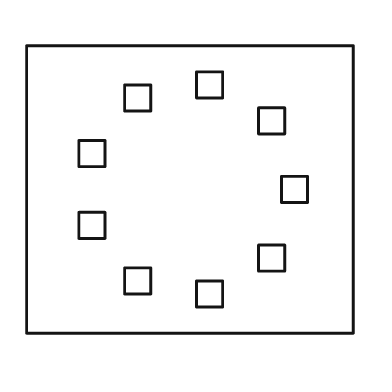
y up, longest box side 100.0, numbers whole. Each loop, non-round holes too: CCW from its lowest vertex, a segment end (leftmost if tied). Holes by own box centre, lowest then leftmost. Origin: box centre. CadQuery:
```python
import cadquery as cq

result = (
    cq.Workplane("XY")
    .moveTo(-50.0, -44.0)
    .lineTo(50.0, -44.0)
    .lineTo(50.0, 44.0)
    .lineTo(-50.0, 44.0)
    .close()
    .moveTo(2.0, -36.0)
    .lineTo(10.0, -36.0)
    .lineTo(10.0, -28.0)
    .lineTo(2.0, -28.0)
    .close()
    .moveTo(-20.0, -32.0)
    .lineTo(-12.0, -32.0)
    .lineTo(-12.0, -24.0)
    .lineTo(-20.0, -24.0)
    .close()
    .moveTo(21.0, -25.0)
    .lineTo(29.0, -25.0)
    .lineTo(29.0, -17.0)
    .lineTo(21.0, -17.0)
    .close()
    .moveTo(-34.0, -15.0)
    .lineTo(-26.0, -15.0)
    .lineTo(-26.0, -7.0)
    .lineTo(-34.0, -7.0)
    .close()
    .moveTo(28.0, -4.0)
    .lineTo(36.0, -4.0)
    .lineTo(36.0, 4.0)
    .lineTo(28.0, 4.0)
    .close()
    .moveTo(-34.0, 7.0)
    .lineTo(-26.0, 7.0)
    .lineTo(-26.0, 15.0)
    .lineTo(-34.0, 15.0)
    .close()
    .moveTo(21.0, 17.0)
    .lineTo(29.0, 17.0)
    .lineTo(29.0, 25.0)
    .lineTo(21.0, 25.0)
    .close()
    .moveTo(-20.0, 24.0)
    .lineTo(-12.0, 24.0)
    .lineTo(-12.0, 32.0)
    .lineTo(-20.0, 32.0)
    .close()
    .moveTo(2.0, 28.0)
    .lineTo(10.0, 28.0)
    .lineTo(10.0, 36.0)
    .lineTo(2.0, 36.0)
    .close()
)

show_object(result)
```